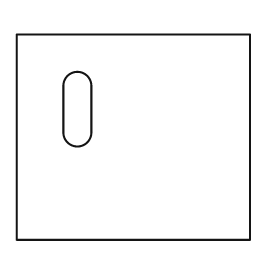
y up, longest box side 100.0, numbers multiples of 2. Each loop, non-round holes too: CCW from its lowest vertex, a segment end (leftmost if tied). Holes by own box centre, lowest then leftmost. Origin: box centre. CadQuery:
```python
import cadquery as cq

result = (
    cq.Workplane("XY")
    .moveTo(-50.0, -44.0)
    .lineTo(50.0, -44.0)
    .lineTo(50.0, 44.0)
    .lineTo(-50.0, 44.0)
    .close()
    .moveTo(-30.0, 2.0)
    .threePointArc((-24.0, -4.0), (-18.0, 2.0))
    .lineTo(-18.0, 22.0)
    .threePointArc((-24.0, 28.0), (-30.0, 22.0))
    .close()
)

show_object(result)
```